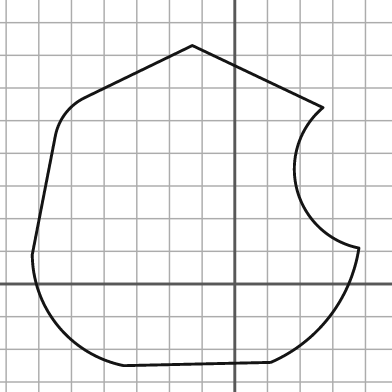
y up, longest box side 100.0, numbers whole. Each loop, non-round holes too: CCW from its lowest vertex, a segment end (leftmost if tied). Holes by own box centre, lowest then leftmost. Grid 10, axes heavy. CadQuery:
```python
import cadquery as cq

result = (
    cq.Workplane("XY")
    .moveTo(-34.0, -25.0)
    .lineTo(11.0, -24.0)
    .threePointArc((29.0, -10.0), (38.0, 11.0))
    .threePointArc((19.0, 29.0), (27.0, 54.0))
    .lineTo(-13.0, 73.0)
    .lineTo(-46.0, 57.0)
    .threePointArc((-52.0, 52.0), (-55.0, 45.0))
    .lineTo(-62.0, 9.0)
    .threePointArc((-54.0, -13.0), (-34.0, -25.0))
    .close()
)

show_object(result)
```